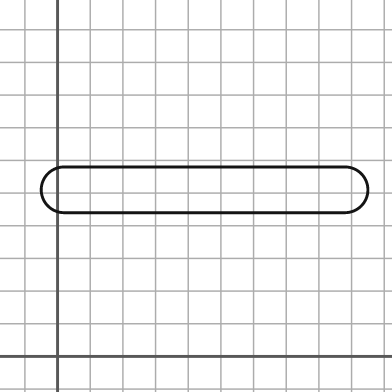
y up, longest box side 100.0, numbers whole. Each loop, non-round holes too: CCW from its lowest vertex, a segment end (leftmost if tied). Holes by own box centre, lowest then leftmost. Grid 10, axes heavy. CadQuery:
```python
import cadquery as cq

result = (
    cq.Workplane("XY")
    .moveTo(2.0, 44.0)
    .lineTo(88.0, 44.0)
    .threePointArc((95.0, 51.0), (88.0, 58.0))
    .lineTo(2.0, 58.0)
    .threePointArc((-5.0, 51.0), (2.0, 44.0))
    .close()
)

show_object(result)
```